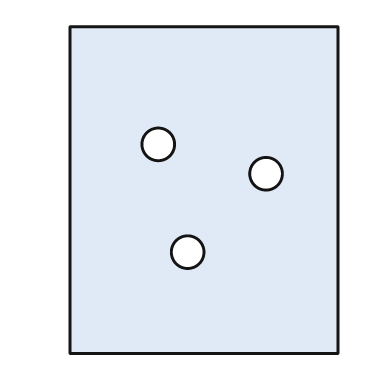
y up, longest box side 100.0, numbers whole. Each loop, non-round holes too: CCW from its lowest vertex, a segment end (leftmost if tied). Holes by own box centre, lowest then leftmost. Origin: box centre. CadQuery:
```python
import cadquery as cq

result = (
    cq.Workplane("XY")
    .moveTo(-41.0, -50.0)
    .lineTo(41.0, -50.0)
    .lineTo(41.0, 50.0)
    .lineTo(-41.0, 50.0)
    .close()
    .moveTo(-5.0, -19.0)
    .circle(5.0)
    .moveTo(19.0, 5.0)
    .circle(5.0)
    .moveTo(-14.0, 14.0)
    .circle(5.0)
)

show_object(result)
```